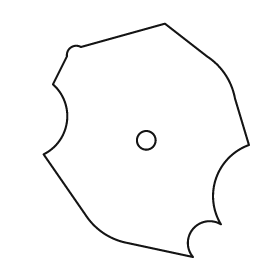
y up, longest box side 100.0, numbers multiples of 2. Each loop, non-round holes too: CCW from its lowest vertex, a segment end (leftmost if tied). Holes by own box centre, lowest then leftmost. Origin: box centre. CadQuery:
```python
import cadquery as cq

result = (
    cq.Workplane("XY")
    .moveTo(20.0, -50.0)
    .threePointArc((20.0, -38.0), (32.0, -36.0))
    .threePointArc((30.0, -16.0), (44.0, -2.0))
    .lineTo(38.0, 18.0)
    .threePointArc((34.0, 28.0), (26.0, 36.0))
    .lineTo(8.0, 50.0)
    .lineTo(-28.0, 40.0)
    .threePointArc((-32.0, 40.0), (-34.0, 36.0))
    .lineTo(-40.0, 24.0)
    .threePointArc((-34.0, 8.0), (-44.0, -6.0))
    .lineTo(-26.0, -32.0)
    .threePointArc((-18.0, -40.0), (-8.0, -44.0))
    .close()
    .moveTo(0.0, 0.0)
    .circle(4.0)
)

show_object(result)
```